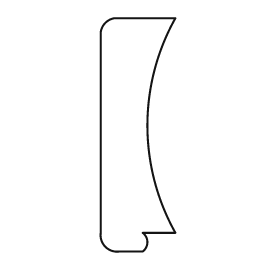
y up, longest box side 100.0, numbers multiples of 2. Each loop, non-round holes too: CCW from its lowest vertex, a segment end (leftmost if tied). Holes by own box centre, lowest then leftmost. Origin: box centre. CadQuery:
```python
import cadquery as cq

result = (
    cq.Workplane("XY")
    .moveTo(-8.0, -50.0)
    .lineTo(2.0, -50.0)
    .threePointArc((4.0, -46.0), (2.0, -42.0))
    .lineTo(16.0, -42.0)
    .threePointArc((4.0, 4.0), (16.0, 50.0))
    .lineTo(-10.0, 50.0)
    .threePointArc((-14.0, 48.0), (-16.0, 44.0))
    .lineTo(-16.0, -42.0)
    .threePointArc((-14.0, -48.0), (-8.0, -50.0))
    .close()
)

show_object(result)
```